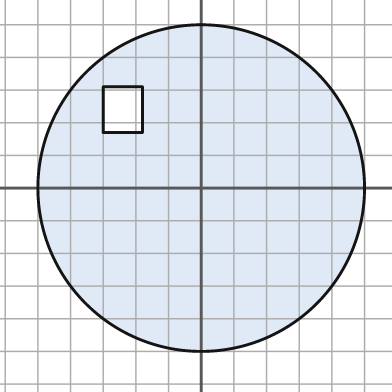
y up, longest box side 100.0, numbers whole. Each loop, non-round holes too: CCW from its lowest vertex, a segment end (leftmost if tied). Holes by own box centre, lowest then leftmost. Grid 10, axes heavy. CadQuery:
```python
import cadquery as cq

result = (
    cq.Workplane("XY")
    .moveTo(0.0, 0.0)
    .circle(50.0)
    .moveTo(-30.0, 17.0)
    .lineTo(-18.0, 17.0)
    .lineTo(-18.0, 31.0)
    .lineTo(-30.0, 31.0)
    .close()
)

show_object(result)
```